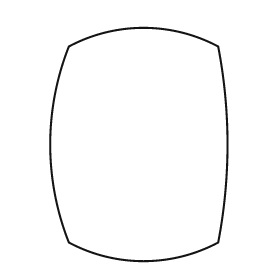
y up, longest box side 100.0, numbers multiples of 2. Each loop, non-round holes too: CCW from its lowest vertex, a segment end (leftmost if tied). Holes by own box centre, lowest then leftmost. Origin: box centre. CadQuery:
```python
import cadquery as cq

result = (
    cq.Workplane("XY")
    .moveTo(-30.0, -42.0)
    .threePointArc((2.0, -50.0), (34.0, -42.0))
    .threePointArc((38.0, 0.0), (34.0, 42.0))
    .threePointArc((2.0, 50.0), (-30.0, 42.0))
    .threePointArc((-38.0, 0.0), (-30.0, -42.0))
    .close()
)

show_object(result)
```